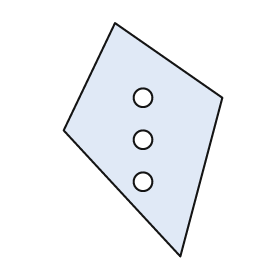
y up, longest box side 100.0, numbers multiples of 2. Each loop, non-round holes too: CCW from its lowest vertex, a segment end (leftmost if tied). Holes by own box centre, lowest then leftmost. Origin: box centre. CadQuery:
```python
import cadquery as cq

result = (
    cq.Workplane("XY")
    .moveTo(16.0, -50.0)
    .lineTo(34.0, 18.0)
    .lineTo(-12.0, 50.0)
    .lineTo(-34.0, 4.0)
    .close()
    .moveTo(0.0, -18.0)
    .circle(4.0)
    .moveTo(0.0, 0.0)
    .circle(4.0)
    .moveTo(0.0, 18.0)
    .circle(4.0)
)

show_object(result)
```